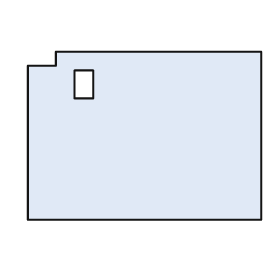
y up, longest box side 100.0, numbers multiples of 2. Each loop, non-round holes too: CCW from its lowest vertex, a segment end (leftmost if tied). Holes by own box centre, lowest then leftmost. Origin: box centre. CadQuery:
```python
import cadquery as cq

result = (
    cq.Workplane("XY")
    .moveTo(-50.0, -36.0)
    .lineTo(50.0, -36.0)
    .lineTo(50.0, 36.0)
    .lineTo(-38.0, 36.0)
    .lineTo(-38.0, 30.0)
    .lineTo(-50.0, 30.0)
    .close()
    .moveTo(-30.0, 16.0)
    .lineTo(-22.0, 16.0)
    .lineTo(-22.0, 28.0)
    .lineTo(-30.0, 28.0)
    .close()
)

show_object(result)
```